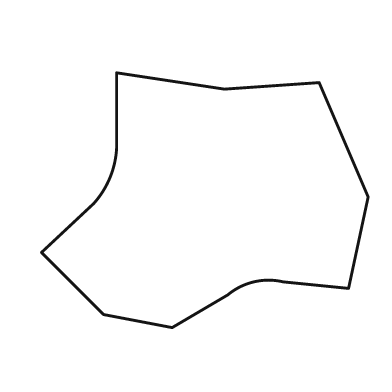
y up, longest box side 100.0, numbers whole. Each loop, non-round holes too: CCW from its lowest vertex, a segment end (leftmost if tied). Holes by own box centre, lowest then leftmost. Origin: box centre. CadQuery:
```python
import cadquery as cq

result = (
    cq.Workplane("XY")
    .moveTo(-10.0, -39.0)
    .lineTo(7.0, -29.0)
    .threePointArc((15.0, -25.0), (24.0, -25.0))
    .lineTo(44.0, -27.0)
    .lineTo(50.0, 1.0)
    .lineTo(35.0, 36.0)
    .lineTo(6.0, 34.0)
    .lineTo(-27.0, 39.0)
    .lineTo(-27.0, 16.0)
    .threePointArc((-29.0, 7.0), (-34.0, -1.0))
    .lineTo(-50.0, -16.0)
    .lineTo(-31.0, -35.0)
    .close()
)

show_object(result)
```